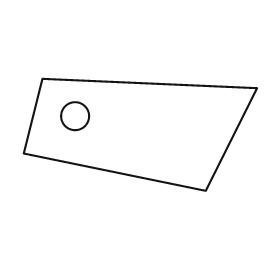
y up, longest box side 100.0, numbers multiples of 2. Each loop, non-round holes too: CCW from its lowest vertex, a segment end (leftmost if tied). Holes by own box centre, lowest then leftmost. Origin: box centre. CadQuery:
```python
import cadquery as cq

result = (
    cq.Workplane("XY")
    .moveTo(28.0, -24.0)
    .lineTo(50.0, 20.0)
    .lineTo(-42.0, 24.0)
    .lineTo(-50.0, -8.0)
    .close()
    .moveTo(-28.0, 8.0)
    .circle(6.0)
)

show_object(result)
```